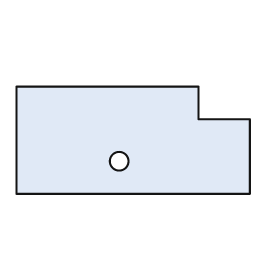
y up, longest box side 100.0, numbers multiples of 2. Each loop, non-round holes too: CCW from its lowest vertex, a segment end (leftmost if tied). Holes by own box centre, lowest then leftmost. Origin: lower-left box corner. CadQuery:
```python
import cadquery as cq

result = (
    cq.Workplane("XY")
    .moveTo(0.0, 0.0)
    .lineTo(100.0, 0.0)
    .lineTo(100.0, 32.0)
    .lineTo(78.0, 32.0)
    .lineTo(78.0, 46.0)
    .lineTo(0.0, 46.0)
    .close()
    .moveTo(44.0, 14.0)
    .circle(4.0)
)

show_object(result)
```